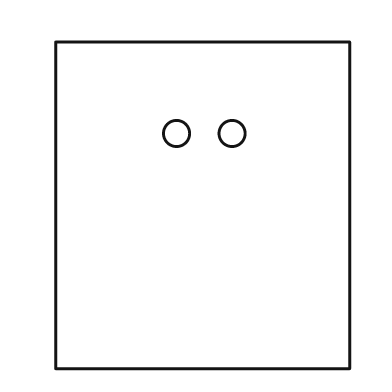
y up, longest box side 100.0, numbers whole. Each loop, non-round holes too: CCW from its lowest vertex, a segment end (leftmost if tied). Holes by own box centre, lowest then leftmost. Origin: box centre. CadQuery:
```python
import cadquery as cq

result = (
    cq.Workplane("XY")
    .moveTo(-45.0, -50.0)
    .lineTo(45.0, -50.0)
    .lineTo(45.0, 50.0)
    .lineTo(-45.0, 50.0)
    .close()
    .moveTo(-8.0, 22.0)
    .circle(4.0)
    .moveTo(9.0, 22.0)
    .circle(4.0)
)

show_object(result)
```